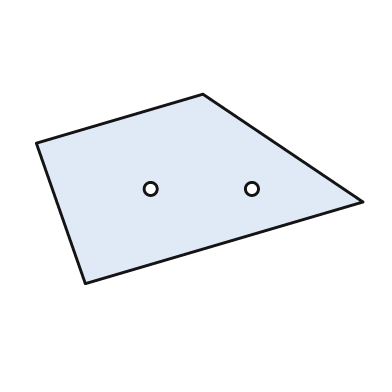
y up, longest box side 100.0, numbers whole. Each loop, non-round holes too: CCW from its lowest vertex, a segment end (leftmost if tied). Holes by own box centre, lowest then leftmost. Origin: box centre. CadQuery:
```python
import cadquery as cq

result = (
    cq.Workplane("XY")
    .moveTo(-35.0, -29.0)
    .lineTo(50.0, -4.0)
    .lineTo(1.0, 29.0)
    .lineTo(-50.0, 14.0)
    .close()
    .moveTo(-15.0, 0.0)
    .circle(2.0)
    .moveTo(16.0, 0.0)
    .circle(2.0)
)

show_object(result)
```